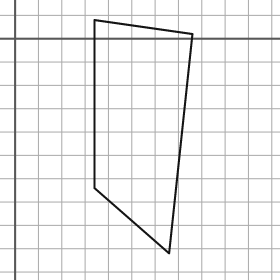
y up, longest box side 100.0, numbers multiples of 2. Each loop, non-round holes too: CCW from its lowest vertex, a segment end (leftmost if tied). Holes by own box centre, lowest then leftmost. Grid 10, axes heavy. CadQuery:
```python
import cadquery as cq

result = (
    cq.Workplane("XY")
    .moveTo(66.0, -92.0)
    .lineTo(76.0, 2.0)
    .lineTo(34.0, 8.0)
    .lineTo(34.0, -64.0)
    .close()
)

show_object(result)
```